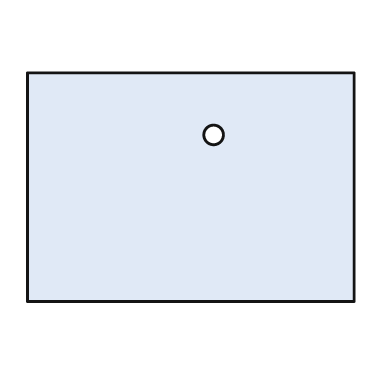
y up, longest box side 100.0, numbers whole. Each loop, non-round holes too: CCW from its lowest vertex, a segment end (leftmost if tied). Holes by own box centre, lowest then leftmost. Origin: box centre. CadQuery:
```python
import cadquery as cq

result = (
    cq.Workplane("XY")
    .moveTo(-50.0, -35.0)
    .lineTo(50.0, -35.0)
    .lineTo(50.0, 35.0)
    .lineTo(-50.0, 35.0)
    .close()
    .moveTo(7.0, 16.0)
    .circle(3.0)
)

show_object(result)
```